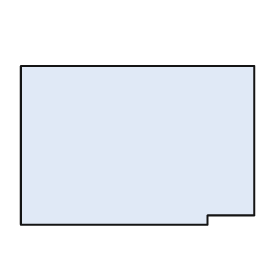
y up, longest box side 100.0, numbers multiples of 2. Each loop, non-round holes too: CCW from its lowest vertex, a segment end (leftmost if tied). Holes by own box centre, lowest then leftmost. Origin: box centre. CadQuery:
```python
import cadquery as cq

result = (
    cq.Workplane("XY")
    .moveTo(-50.0, -34.0)
    .lineTo(30.0, -34.0)
    .lineTo(30.0, -30.0)
    .lineTo(50.0, -30.0)
    .lineTo(50.0, 34.0)
    .lineTo(-50.0, 34.0)
    .close()
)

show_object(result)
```